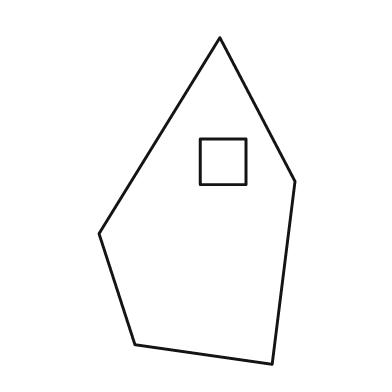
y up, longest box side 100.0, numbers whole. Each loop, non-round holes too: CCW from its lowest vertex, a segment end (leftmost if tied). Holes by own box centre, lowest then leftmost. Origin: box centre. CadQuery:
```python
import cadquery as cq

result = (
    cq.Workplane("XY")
    .moveTo(23.0, -50.0)
    .lineTo(30.0, 6.0)
    .lineTo(7.0, 50.0)
    .lineTo(-30.0, -10.0)
    .lineTo(-19.0, -44.0)
    .close()
    .moveTo(1.0, 5.0)
    .lineTo(15.0, 5.0)
    .lineTo(15.0, 19.0)
    .lineTo(1.0, 19.0)
    .close()
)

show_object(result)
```